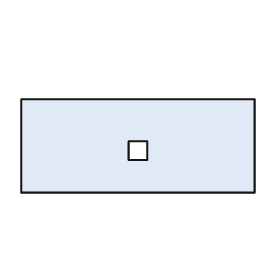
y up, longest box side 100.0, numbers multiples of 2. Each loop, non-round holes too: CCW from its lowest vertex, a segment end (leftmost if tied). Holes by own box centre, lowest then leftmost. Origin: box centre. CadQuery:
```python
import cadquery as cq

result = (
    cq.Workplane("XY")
    .moveTo(-50.0, -20.0)
    .lineTo(50.0, -20.0)
    .lineTo(50.0, 20.0)
    .lineTo(-50.0, 20.0)
    .close()
    .moveTo(-4.0, -6.0)
    .lineTo(4.0, -6.0)
    .lineTo(4.0, 2.0)
    .lineTo(-4.0, 2.0)
    .close()
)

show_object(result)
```